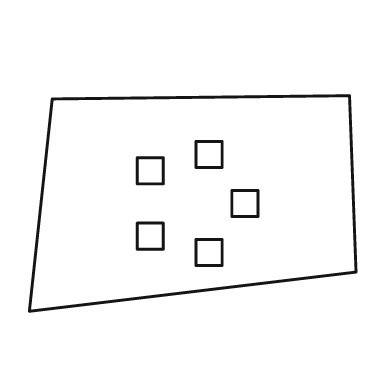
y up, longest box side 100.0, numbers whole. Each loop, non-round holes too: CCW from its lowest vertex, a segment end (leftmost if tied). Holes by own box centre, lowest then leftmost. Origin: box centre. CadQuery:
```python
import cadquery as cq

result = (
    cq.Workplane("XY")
    .moveTo(-50.0, -33.0)
    .lineTo(50.0, -21.0)
    .lineTo(48.0, 33.0)
    .lineTo(-43.0, 32.0)
    .close()
    .moveTo(1.0, -19.0)
    .lineTo(9.0, -19.0)
    .lineTo(9.0, -11.0)
    .lineTo(1.0, -11.0)
    .close()
    .moveTo(-17.0, -14.0)
    .lineTo(-9.0, -14.0)
    .lineTo(-9.0, -6.0)
    .lineTo(-17.0, -6.0)
    .close()
    .moveTo(12.0, -4.0)
    .lineTo(20.0, -4.0)
    .lineTo(20.0, 4.0)
    .lineTo(12.0, 4.0)
    .close()
    .moveTo(-17.0, 6.0)
    .lineTo(-9.0, 6.0)
    .lineTo(-9.0, 14.0)
    .lineTo(-17.0, 14.0)
    .close()
    .moveTo(1.0, 11.0)
    .lineTo(9.0, 11.0)
    .lineTo(9.0, 19.0)
    .lineTo(1.0, 19.0)
    .close()
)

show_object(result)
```